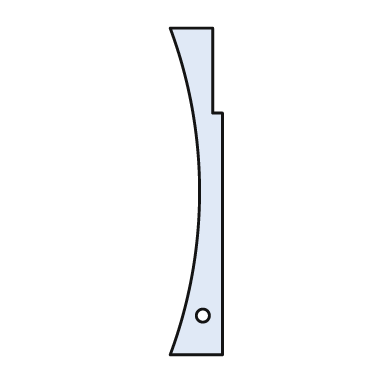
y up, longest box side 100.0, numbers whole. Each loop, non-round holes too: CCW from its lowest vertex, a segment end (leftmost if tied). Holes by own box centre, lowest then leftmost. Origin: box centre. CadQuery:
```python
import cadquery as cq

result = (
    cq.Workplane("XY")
    .moveTo(-8.0, -50.0)
    .lineTo(8.0, -50.0)
    .lineTo(8.0, 24.0)
    .lineTo(5.0, 24.0)
    .lineTo(5.0, 50.0)
    .lineTo(-8.0, 50.0)
    .threePointArc((1.0, 0.0), (-8.0, -50.0))
    .close()
    .moveTo(2.0, -38.0)
    .circle(2.0)
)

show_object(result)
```